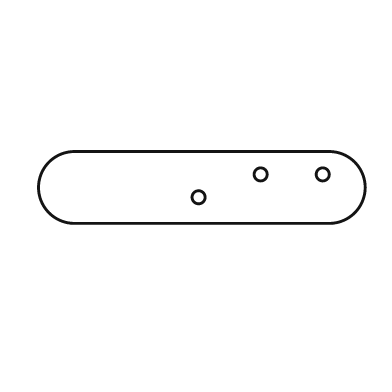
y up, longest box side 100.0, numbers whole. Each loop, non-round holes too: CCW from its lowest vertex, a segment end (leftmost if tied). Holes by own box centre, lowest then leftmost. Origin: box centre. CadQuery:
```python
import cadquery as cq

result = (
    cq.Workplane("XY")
    .moveTo(-39.0, -11.0)
    .lineTo(39.0, -11.0)
    .threePointArc((50.0, 0.0), (39.0, 11.0))
    .lineTo(-39.0, 11.0)
    .threePointArc((-50.0, 0.0), (-39.0, -11.0))
    .close()
    .moveTo(-1.0, -3.0)
    .circle(2.0)
    .moveTo(18.0, 4.0)
    .circle(2.0)
    .moveTo(37.0, 4.0)
    .circle(2.0)
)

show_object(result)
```